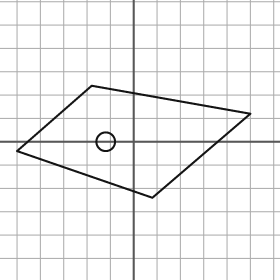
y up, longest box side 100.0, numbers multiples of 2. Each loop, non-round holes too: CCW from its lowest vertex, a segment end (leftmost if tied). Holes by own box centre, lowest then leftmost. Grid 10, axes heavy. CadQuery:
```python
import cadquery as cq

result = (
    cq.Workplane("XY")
    .moveTo(8.0, -24.0)
    .lineTo(50.0, 12.0)
    .lineTo(-18.0, 24.0)
    .lineTo(-50.0, -4.0)
    .close()
    .moveTo(-12.0, 0.0)
    .circle(4.0)
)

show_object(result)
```